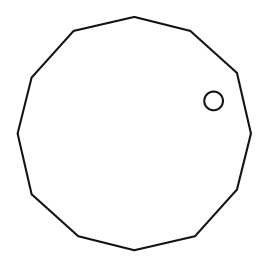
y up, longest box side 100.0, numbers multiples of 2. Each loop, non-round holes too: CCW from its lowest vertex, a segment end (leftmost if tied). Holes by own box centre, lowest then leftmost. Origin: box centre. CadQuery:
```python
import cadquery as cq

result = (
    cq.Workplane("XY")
    .moveTo(0.0, -50.0)
    .lineTo(26.0, -44.0)
    .lineTo(44.0, -24.0)
    .lineTo(50.0, 0.0)
    .lineTo(44.0, 26.0)
    .lineTo(24.0, 44.0)
    .lineTo(0.0, 50.0)
    .lineTo(-26.0, 44.0)
    .lineTo(-44.0, 24.0)
    .lineTo(-50.0, 0.0)
    .lineTo(-44.0, -26.0)
    .lineTo(-24.0, -44.0)
    .close()
    .moveTo(34.0, 14.0)
    .circle(4.0)
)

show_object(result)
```